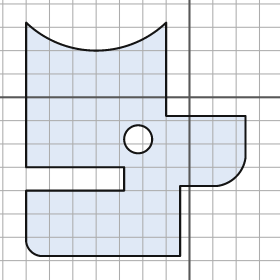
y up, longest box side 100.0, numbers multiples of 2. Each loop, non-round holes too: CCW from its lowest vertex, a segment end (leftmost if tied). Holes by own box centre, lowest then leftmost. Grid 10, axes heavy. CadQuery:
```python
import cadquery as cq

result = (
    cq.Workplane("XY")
    .moveTo(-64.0, -68.0)
    .lineTo(-4.0, -68.0)
    .lineTo(-4.0, -38.0)
    .lineTo(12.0, -38.0)
    .threePointArc((20.0, -34.0), (24.0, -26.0))
    .lineTo(24.0, -8.0)
    .lineTo(-10.0, -8.0)
    .lineTo(-10.0, 32.0)
    .threePointArc((-40.0, 20.0), (-70.0, 32.0))
    .lineTo(-70.0, -30.0)
    .lineTo(-28.0, -30.0)
    .lineTo(-28.0, -40.0)
    .lineTo(-70.0, -40.0)
    .lineTo(-70.0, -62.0)
    .threePointArc((-68.0, -66.0), (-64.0, -68.0))
    .close()
    .moveTo(-22.0, -18.0)
    .circle(6.0)
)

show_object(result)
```